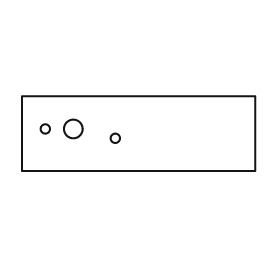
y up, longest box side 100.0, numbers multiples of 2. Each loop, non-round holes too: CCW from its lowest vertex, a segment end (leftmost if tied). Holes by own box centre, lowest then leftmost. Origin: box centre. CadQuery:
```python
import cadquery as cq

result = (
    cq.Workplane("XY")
    .moveTo(-50.0, -16.0)
    .lineTo(50.0, -16.0)
    .lineTo(50.0, 16.0)
    .lineTo(-50.0, 16.0)
    .close()
    .moveTo(-10.0, -2.0)
    .circle(2.0)
    .moveTo(-40.0, 2.0)
    .circle(2.0)
    .moveTo(-28.0, 2.0)
    .circle(4.0)
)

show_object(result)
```